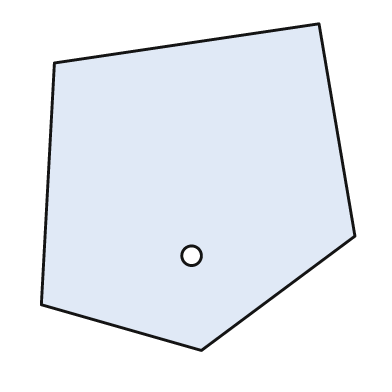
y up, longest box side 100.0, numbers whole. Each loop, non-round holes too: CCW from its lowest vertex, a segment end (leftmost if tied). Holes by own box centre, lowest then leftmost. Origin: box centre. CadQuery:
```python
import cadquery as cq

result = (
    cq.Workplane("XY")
    .moveTo(1.0, -50.0)
    .lineTo(48.0, -15.0)
    .lineTo(37.0, 50.0)
    .lineTo(-44.0, 38.0)
    .lineTo(-48.0, -36.0)
    .close()
    .moveTo(-2.0, -21.0)
    .circle(3.0)
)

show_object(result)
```